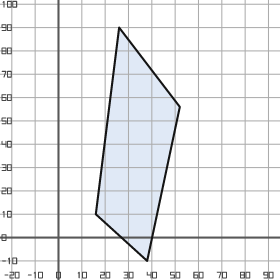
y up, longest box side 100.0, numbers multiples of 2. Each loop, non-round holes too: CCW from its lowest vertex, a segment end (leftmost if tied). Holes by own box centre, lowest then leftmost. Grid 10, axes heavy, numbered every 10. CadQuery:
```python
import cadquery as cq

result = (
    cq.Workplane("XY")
    .moveTo(38.0, -10.0)
    .lineTo(52.0, 56.0)
    .lineTo(26.0, 90.0)
    .lineTo(16.0, 10.0)
    .close()
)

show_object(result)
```